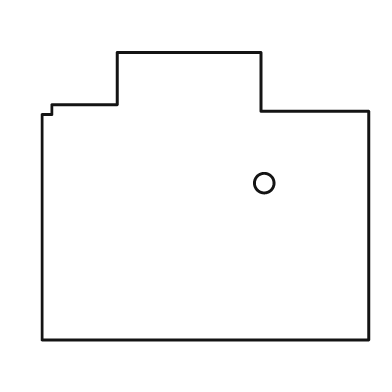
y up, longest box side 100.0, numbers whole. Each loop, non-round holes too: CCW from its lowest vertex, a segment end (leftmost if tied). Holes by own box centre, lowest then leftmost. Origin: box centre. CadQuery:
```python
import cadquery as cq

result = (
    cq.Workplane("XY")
    .moveTo(-50.0, -44.0)
    .lineTo(50.0, -44.0)
    .lineTo(50.0, 26.0)
    .lineTo(17.0, 26.0)
    .lineTo(17.0, 44.0)
    .lineTo(-27.0, 44.0)
    .lineTo(-27.0, 28.0)
    .lineTo(-47.0, 28.0)
    .lineTo(-47.0, 25.0)
    .lineTo(-50.0, 25.0)
    .close()
    .moveTo(18.0, 4.0)
    .circle(3.0)
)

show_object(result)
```